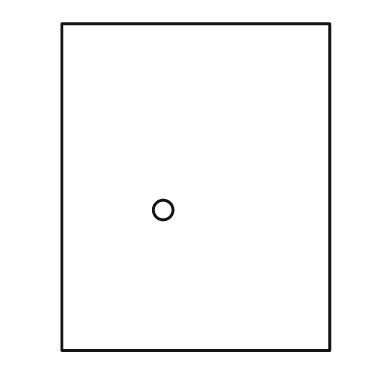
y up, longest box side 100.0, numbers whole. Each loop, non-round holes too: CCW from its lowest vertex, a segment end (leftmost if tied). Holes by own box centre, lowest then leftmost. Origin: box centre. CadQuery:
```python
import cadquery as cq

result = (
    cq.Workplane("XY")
    .moveTo(-41.0, -50.0)
    .lineTo(41.0, -50.0)
    .lineTo(41.0, 50.0)
    .lineTo(-41.0, 50.0)
    .close()
    .moveTo(-10.0, -7.0)
    .circle(3.0)
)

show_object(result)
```